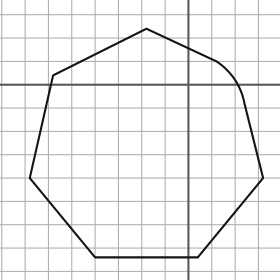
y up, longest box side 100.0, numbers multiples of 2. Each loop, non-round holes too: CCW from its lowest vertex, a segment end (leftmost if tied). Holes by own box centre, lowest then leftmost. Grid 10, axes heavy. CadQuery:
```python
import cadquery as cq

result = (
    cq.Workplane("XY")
    .moveTo(-40.0, -74.0)
    .lineTo(4.0, -74.0)
    .lineTo(32.0, -40.0)
    .lineTo(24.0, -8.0)
    .threePointArc((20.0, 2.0), (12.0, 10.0))
    .lineTo(-18.0, 24.0)
    .lineTo(-58.0, 4.0)
    .lineTo(-68.0, -40.0)
    .close()
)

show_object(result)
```